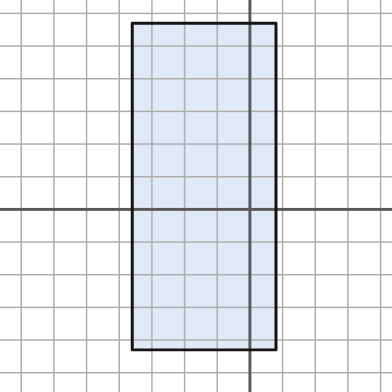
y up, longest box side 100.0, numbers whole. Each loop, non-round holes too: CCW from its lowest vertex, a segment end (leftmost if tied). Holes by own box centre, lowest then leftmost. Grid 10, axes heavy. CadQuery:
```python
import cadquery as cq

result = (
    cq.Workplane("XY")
    .moveTo(-36.0, -43.0)
    .lineTo(8.0, -43.0)
    .lineTo(8.0, 57.0)
    .lineTo(-36.0, 57.0)
    .close()
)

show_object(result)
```